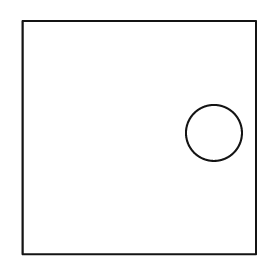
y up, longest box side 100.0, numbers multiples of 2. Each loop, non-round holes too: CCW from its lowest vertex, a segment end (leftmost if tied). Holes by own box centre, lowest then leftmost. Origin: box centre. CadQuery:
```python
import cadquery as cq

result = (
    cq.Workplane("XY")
    .moveTo(-50.0, -50.0)
    .lineTo(50.0, -50.0)
    .lineTo(50.0, 50.0)
    .lineTo(-50.0, 50.0)
    .close()
    .moveTo(32.0, 2.0)
    .circle(12.0)
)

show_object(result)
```